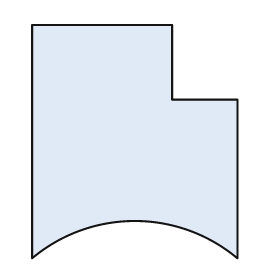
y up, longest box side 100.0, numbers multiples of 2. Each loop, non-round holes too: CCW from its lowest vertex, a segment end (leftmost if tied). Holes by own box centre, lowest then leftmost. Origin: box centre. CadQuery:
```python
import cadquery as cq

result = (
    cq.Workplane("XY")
    .moveTo(-44.0, -50.0)
    .threePointArc((0.0, -34.0), (44.0, -50.0))
    .lineTo(44.0, 18.0)
    .lineTo(16.0, 18.0)
    .lineTo(16.0, 50.0)
    .lineTo(-44.0, 50.0)
    .close()
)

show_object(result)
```